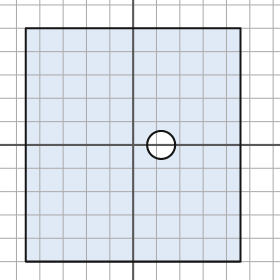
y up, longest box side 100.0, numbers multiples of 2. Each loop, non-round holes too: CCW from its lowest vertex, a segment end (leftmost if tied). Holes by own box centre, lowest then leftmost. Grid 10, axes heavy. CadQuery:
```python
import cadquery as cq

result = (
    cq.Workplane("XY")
    .moveTo(-46.0, -50.0)
    .lineTo(46.0, -50.0)
    .lineTo(46.0, 50.0)
    .lineTo(-46.0, 50.0)
    .close()
    .moveTo(12.0, 0.0)
    .circle(6.0)
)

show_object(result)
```